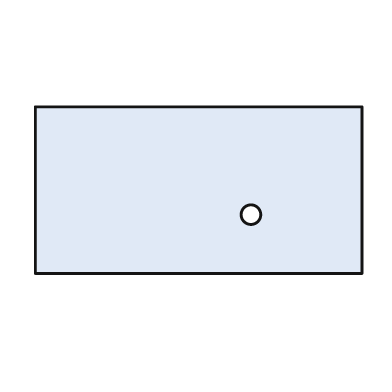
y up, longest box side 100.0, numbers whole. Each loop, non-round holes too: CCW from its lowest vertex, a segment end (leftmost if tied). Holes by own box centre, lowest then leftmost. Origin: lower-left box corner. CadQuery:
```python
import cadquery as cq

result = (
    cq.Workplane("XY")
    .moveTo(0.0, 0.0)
    .lineTo(100.0, 0.0)
    .lineTo(100.0, 51.0)
    .lineTo(0.0, 51.0)
    .close()
    .moveTo(66.0, 18.0)
    .circle(3.0)
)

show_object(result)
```